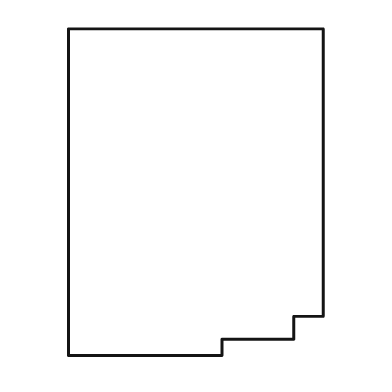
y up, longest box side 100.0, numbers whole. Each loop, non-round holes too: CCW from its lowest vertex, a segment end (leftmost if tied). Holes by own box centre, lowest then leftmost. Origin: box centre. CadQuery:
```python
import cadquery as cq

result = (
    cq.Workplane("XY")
    .moveTo(-39.0, -50.0)
    .lineTo(8.0, -50.0)
    .lineTo(8.0, -45.0)
    .lineTo(30.0, -45.0)
    .lineTo(30.0, -38.0)
    .lineTo(39.0, -38.0)
    .lineTo(39.0, 50.0)
    .lineTo(-39.0, 50.0)
    .close()
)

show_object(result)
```